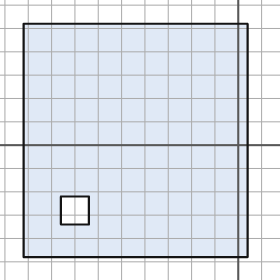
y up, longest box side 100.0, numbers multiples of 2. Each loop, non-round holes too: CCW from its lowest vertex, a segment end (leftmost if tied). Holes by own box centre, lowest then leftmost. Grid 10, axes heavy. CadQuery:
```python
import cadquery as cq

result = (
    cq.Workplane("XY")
    .moveTo(-92.0, -48.0)
    .lineTo(4.0, -48.0)
    .lineTo(4.0, 52.0)
    .lineTo(-92.0, 52.0)
    .close()
    .moveTo(-76.0, -34.0)
    .lineTo(-64.0, -34.0)
    .lineTo(-64.0, -22.0)
    .lineTo(-76.0, -22.0)
    .close()
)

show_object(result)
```